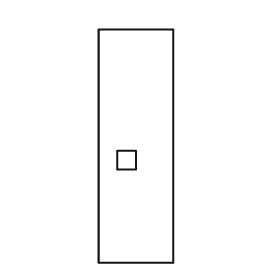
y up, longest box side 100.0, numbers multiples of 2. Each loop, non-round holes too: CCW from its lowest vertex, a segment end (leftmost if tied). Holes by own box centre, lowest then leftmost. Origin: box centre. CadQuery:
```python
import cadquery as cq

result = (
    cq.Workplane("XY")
    .moveTo(-16.0, -50.0)
    .lineTo(16.0, -50.0)
    .lineTo(16.0, 50.0)
    .lineTo(-16.0, 50.0)
    .close()
    .moveTo(-8.0, -10.0)
    .lineTo(0.0, -10.0)
    .lineTo(0.0, -2.0)
    .lineTo(-8.0, -2.0)
    .close()
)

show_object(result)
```